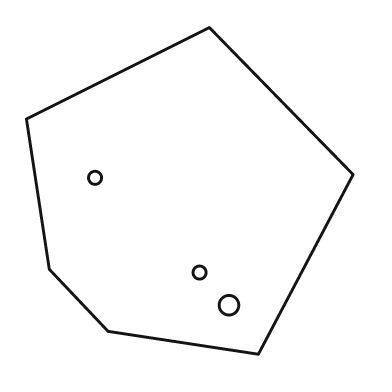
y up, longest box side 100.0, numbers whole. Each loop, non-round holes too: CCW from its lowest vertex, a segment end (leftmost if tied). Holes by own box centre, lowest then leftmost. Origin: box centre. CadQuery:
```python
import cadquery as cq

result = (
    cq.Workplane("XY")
    .moveTo(21.0, -50.0)
    .lineTo(50.0, 5.0)
    .lineTo(6.0, 50.0)
    .lineTo(-50.0, 22.0)
    .lineTo(-43.0, -24.0)
    .lineTo(-25.0, -43.0)
    .close()
    .moveTo(12.0, -35.0)
    .circle(3.0)
    .moveTo(3.0, -25.0)
    .circle(2.0)
    .moveTo(-29.0, 4.0)
    .circle(2.0)
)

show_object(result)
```